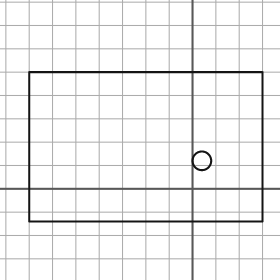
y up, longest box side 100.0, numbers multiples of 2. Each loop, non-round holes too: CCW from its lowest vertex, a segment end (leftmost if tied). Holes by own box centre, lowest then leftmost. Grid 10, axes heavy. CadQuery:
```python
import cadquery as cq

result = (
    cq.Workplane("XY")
    .moveTo(-70.0, -14.0)
    .lineTo(30.0, -14.0)
    .lineTo(30.0, 50.0)
    .lineTo(-70.0, 50.0)
    .close()
    .moveTo(4.0, 12.0)
    .circle(4.0)
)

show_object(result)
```